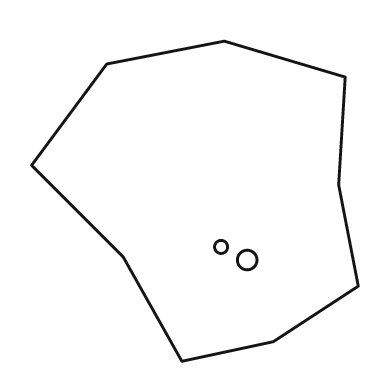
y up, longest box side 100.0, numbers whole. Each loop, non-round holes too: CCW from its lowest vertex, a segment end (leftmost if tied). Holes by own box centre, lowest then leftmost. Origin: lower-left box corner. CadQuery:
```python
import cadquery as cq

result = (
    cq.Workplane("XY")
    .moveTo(46.0, 0.0)
    .lineTo(74.0, 6.0)
    .lineTo(100.0, 23.0)
    .lineTo(94.0, 54.0)
    .lineTo(96.0, 87.0)
    .lineTo(59.0, 98.0)
    .lineTo(23.0, 91.0)
    .lineTo(0.0, 60.0)
    .lineTo(28.0, 32.0)
    .close()
    .moveTo(66.0, 31.0)
    .circle(3.0)
    .moveTo(58.0, 35.0)
    .circle(2.0)
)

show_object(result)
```